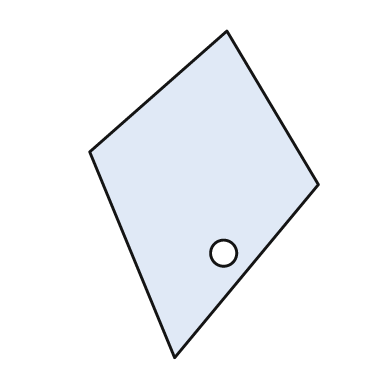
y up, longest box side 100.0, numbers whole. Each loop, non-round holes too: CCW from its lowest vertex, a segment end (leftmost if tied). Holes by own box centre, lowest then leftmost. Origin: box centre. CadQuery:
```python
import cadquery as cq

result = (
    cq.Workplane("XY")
    .moveTo(-9.0, -50.0)
    .lineTo(35.0, 3.0)
    .lineTo(7.0, 50.0)
    .lineTo(-35.0, 13.0)
    .close()
    .moveTo(6.0, -18.0)
    .circle(4.0)
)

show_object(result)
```